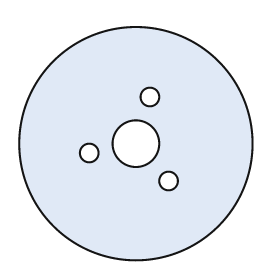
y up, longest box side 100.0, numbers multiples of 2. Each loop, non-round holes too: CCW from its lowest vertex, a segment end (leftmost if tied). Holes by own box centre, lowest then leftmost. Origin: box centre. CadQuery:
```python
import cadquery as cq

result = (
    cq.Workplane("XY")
    .moveTo(0.0, 0.0)
    .circle(50.0)
    .moveTo(14.0, -16.0)
    .circle(4.0)
    .moveTo(-20.0, -4.0)
    .circle(4.0)
    .moveTo(0.0, 0.0)
    .circle(10.0)
    .moveTo(6.0, 20.0)
    .circle(4.0)
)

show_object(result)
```